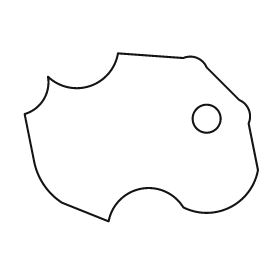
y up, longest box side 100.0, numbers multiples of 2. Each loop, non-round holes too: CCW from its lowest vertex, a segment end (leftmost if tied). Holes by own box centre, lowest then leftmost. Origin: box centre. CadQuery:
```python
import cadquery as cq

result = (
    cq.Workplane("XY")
    .moveTo(-14.0, -36.0)
    .threePointArc((0.0, -22.0), (18.0, -30.0))
    .threePointArc((38.0, -30.0), (50.0, -14.0))
    .lineTo(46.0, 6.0)
    .threePointArc((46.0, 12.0), (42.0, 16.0))
    .lineTo(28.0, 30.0)
    .threePointArc((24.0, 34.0), (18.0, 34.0))
    .lineTo(-10.0, 36.0)
    .threePointArc((-22.0, 22.0), (-40.0, 26.0))
    .threePointArc((-42.0, 16.0), (-50.0, 10.0))
    .lineTo(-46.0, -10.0)
    .threePointArc((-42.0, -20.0), (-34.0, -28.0))
    .close()
    .moveTo(28.0, 8.0)
    .circle(6.0)
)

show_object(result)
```